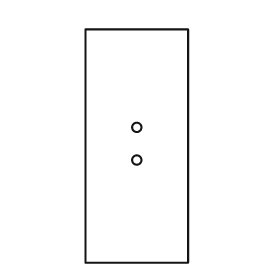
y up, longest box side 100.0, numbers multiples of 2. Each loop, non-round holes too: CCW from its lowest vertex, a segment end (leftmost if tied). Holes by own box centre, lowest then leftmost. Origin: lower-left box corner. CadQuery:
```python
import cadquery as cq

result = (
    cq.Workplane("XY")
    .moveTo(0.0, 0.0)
    .lineTo(44.0, 0.0)
    .lineTo(44.0, 100.0)
    .lineTo(0.0, 100.0)
    .close()
    .moveTo(22.0, 44.0)
    .circle(2.0)
    .moveTo(22.0, 58.0)
    .circle(2.0)
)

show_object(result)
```